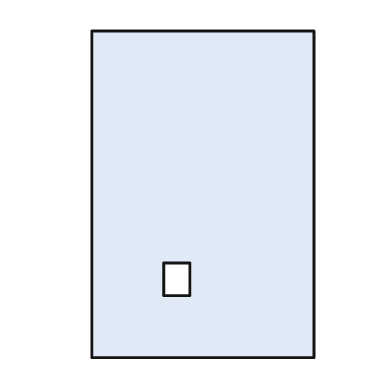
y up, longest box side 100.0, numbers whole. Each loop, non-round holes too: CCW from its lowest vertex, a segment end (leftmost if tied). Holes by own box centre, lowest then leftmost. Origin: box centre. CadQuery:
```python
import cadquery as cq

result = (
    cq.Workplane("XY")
    .moveTo(-34.0, -50.0)
    .lineTo(34.0, -50.0)
    .lineTo(34.0, 50.0)
    .lineTo(-34.0, 50.0)
    .close()
    .moveTo(-12.0, -31.0)
    .lineTo(-4.0, -31.0)
    .lineTo(-4.0, -21.0)
    .lineTo(-12.0, -21.0)
    .close()
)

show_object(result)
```